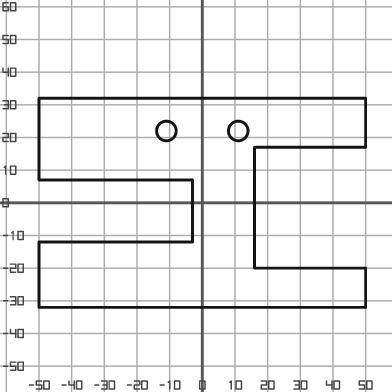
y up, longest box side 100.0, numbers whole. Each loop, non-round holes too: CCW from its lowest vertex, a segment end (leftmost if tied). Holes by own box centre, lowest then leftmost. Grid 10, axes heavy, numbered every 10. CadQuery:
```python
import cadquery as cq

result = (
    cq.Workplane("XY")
    .moveTo(-50.0, -32.0)
    .lineTo(50.0, -32.0)
    .lineTo(50.0, -20.0)
    .lineTo(16.0, -20.0)
    .lineTo(16.0, 17.0)
    .lineTo(50.0, 17.0)
    .lineTo(50.0, 32.0)
    .lineTo(-50.0, 32.0)
    .lineTo(-50.0, 7.0)
    .lineTo(-3.0, 7.0)
    .lineTo(-3.0, -12.0)
    .lineTo(-50.0, -12.0)
    .close()
    .moveTo(-11.0, 22.0)
    .circle(3.0)
    .moveTo(11.0, 22.0)
    .circle(3.0)
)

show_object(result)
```